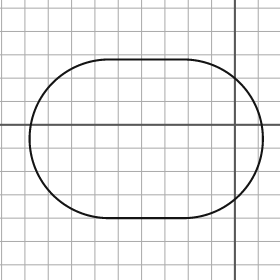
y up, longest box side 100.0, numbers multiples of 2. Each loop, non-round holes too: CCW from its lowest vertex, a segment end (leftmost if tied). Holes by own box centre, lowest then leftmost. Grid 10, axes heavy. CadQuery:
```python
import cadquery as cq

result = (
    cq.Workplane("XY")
    .moveTo(-54.0, -40.0)
    .lineTo(-22.0, -40.0)
    .threePointArc((12.0, -6.0), (-22.0, 28.0))
    .lineTo(-54.0, 28.0)
    .threePointArc((-88.0, -6.0), (-54.0, -40.0))
    .close()
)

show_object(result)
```